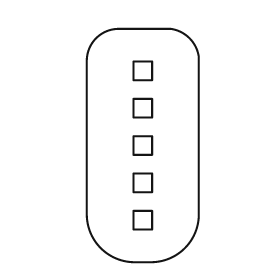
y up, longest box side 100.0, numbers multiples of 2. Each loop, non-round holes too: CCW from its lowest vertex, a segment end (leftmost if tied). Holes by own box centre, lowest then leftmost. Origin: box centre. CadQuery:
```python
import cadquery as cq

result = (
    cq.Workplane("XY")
    .moveTo(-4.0, -50.0)
    .lineTo(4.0, -50.0)
    .threePointArc((18.0, -44.0), (24.0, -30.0))
    .lineTo(24.0, 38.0)
    .threePointArc((20.0, 46.0), (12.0, 50.0))
    .lineTo(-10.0, 50.0)
    .threePointArc((-20.0, 46.0), (-24.0, 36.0))
    .lineTo(-24.0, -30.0)
    .threePointArc((-18.0, -44.0), (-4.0, -50.0))
    .close()
    .moveTo(-4.0, -36.0)
    .lineTo(4.0, -36.0)
    .lineTo(4.0, -28.0)
    .lineTo(-4.0, -28.0)
    .close()
    .moveTo(-4.0, -20.0)
    .lineTo(4.0, -20.0)
    .lineTo(4.0, -12.0)
    .lineTo(-4.0, -12.0)
    .close()
    .moveTo(-4.0, -4.0)
    .lineTo(4.0, -4.0)
    .lineTo(4.0, 4.0)
    .lineTo(-4.0, 4.0)
    .close()
    .moveTo(-4.0, 12.0)
    .lineTo(4.0, 12.0)
    .lineTo(4.0, 20.0)
    .lineTo(-4.0, 20.0)
    .close()
    .moveTo(-4.0, 28.0)
    .lineTo(4.0, 28.0)
    .lineTo(4.0, 36.0)
    .lineTo(-4.0, 36.0)
    .close()
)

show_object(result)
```